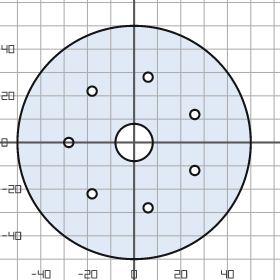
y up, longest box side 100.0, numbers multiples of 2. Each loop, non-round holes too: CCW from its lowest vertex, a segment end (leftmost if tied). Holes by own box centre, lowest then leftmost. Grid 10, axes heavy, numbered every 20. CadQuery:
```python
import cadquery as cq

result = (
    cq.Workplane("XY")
    .moveTo(0.0, 0.0)
    .circle(50.0)
    .moveTo(6.0, -28.0)
    .circle(2.0)
    .moveTo(-18.0, -22.0)
    .circle(2.0)
    .moveTo(26.0, -12.0)
    .circle(2.0)
    .moveTo(-28.0, 0.0)
    .circle(2.0)
    .moveTo(0.0, 0.0)
    .circle(8.0)
    .moveTo(26.0, 12.0)
    .circle(2.0)
    .moveTo(-18.0, 22.0)
    .circle(2.0)
    .moveTo(6.0, 28.0)
    .circle(2.0)
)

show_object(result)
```